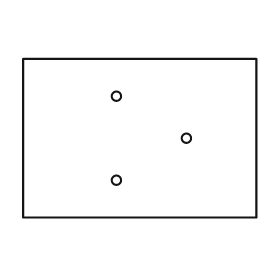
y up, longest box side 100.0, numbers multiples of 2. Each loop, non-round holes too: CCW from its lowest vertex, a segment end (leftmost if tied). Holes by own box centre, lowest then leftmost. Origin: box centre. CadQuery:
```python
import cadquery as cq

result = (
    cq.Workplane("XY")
    .moveTo(-50.0, -34.0)
    .lineTo(50.0, -34.0)
    .lineTo(50.0, 34.0)
    .lineTo(-50.0, 34.0)
    .close()
    .moveTo(-10.0, -18.0)
    .circle(2.0)
    .moveTo(20.0, 0.0)
    .circle(2.0)
    .moveTo(-10.0, 18.0)
    .circle(2.0)
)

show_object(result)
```